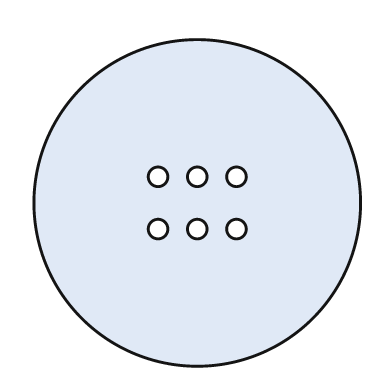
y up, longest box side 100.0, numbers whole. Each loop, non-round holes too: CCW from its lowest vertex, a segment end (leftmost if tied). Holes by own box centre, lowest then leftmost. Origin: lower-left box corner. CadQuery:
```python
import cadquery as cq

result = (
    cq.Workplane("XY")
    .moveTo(50.0, 50.0)
    .circle(50.0)
    .moveTo(38.0, 42.0)
    .circle(3.0)
    .moveTo(50.0, 42.0)
    .circle(3.0)
    .moveTo(62.0, 42.0)
    .circle(3.0)
    .moveTo(38.0, 58.0)
    .circle(3.0)
    .moveTo(50.0, 58.0)
    .circle(3.0)
    .moveTo(62.0, 58.0)
    .circle(3.0)
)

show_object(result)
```